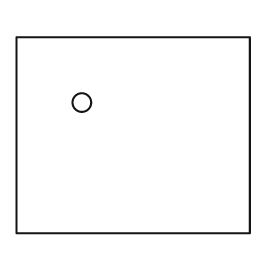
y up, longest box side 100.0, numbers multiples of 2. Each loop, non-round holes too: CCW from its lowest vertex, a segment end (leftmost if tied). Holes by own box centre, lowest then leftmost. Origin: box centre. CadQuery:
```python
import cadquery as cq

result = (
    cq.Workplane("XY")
    .moveTo(-50.0, -42.0)
    .lineTo(50.0, -42.0)
    .lineTo(50.0, 42.0)
    .lineTo(-50.0, 42.0)
    .close()
    .moveTo(-22.0, 14.0)
    .circle(4.0)
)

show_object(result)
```